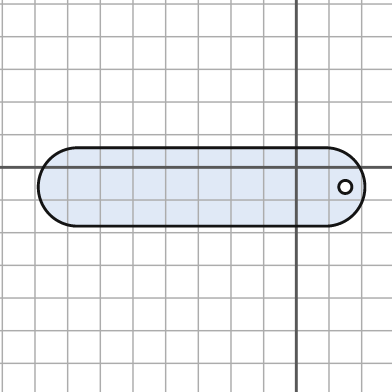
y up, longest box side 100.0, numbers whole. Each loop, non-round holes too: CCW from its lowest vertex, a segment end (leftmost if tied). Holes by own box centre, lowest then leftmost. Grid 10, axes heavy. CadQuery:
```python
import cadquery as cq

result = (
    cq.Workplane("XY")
    .moveTo(-67.0, -18.0)
    .lineTo(9.0, -18.0)
    .threePointArc((21.0, -6.0), (9.0, 6.0))
    .lineTo(-67.0, 6.0)
    .threePointArc((-79.0, -6.0), (-67.0, -18.0))
    .close()
    .moveTo(15.0, -6.0)
    .circle(2.0)
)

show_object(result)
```